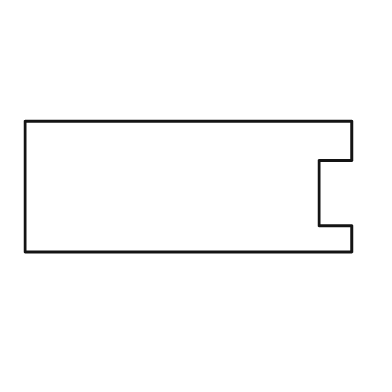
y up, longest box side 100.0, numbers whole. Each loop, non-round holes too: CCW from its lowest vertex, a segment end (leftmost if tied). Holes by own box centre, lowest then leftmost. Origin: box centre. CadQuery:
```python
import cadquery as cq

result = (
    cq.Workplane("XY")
    .moveTo(-50.0, -20.0)
    .lineTo(50.0, -20.0)
    .lineTo(50.0, -12.0)
    .lineTo(40.0, -12.0)
    .lineTo(40.0, 8.0)
    .lineTo(50.0, 8.0)
    .lineTo(50.0, 20.0)
    .lineTo(-50.0, 20.0)
    .close()
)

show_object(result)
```